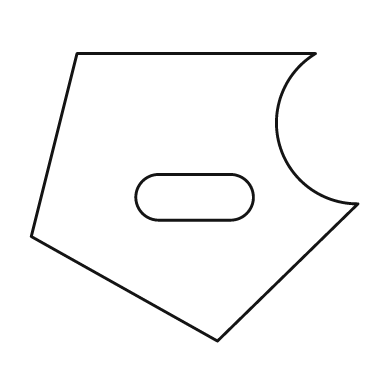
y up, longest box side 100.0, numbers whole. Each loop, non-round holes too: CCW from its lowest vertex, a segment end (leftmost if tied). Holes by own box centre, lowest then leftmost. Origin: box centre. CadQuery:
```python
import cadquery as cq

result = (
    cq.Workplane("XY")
    .moveTo(7.0, -44.0)
    .lineTo(50.0, -2.0)
    .threePointArc((26.0, 16.0), (37.0, 44.0))
    .lineTo(-36.0, 44.0)
    .lineTo(-50.0, -12.0)
    .close()
    .moveTo(-11.0, -7.0)
    .lineTo(11.0, -7.0)
    .threePointArc((18.0, 0.0), (11.0, 7.0))
    .lineTo(-11.0, 7.0)
    .threePointArc((-18.0, 0.0), (-11.0, -7.0))
    .close()
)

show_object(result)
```